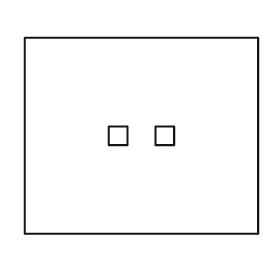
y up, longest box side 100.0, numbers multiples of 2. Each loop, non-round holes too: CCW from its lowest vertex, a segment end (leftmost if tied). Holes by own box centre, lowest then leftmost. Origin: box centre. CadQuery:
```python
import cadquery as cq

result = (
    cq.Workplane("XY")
    .moveTo(-50.0, -42.0)
    .lineTo(50.0, -42.0)
    .lineTo(50.0, 42.0)
    .lineTo(-50.0, 42.0)
    .close()
    .moveTo(-14.0, -4.0)
    .lineTo(-6.0, -4.0)
    .lineTo(-6.0, 4.0)
    .lineTo(-14.0, 4.0)
    .close()
    .moveTo(6.0, -4.0)
    .lineTo(14.0, -4.0)
    .lineTo(14.0, 4.0)
    .lineTo(6.0, 4.0)
    .close()
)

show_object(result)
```